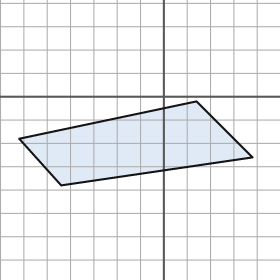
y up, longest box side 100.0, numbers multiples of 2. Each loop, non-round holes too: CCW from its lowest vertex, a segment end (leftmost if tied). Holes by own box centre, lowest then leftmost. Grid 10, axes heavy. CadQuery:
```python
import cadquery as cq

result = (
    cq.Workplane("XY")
    .moveTo(-44.0, -38.0)
    .lineTo(38.0, -26.0)
    .lineTo(14.0, -2.0)
    .lineTo(-62.0, -18.0)
    .close()
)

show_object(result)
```